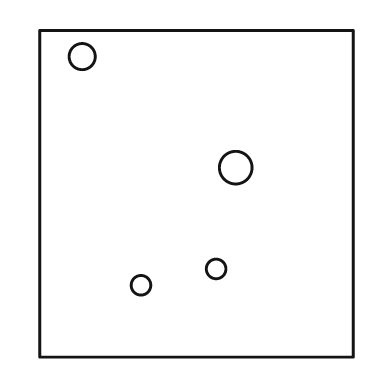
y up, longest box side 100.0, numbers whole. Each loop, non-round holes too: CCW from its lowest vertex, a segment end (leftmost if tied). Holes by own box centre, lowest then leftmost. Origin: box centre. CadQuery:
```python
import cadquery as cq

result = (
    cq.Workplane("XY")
    .moveTo(-48.0, -50.0)
    .lineTo(48.0, -50.0)
    .lineTo(48.0, 50.0)
    .lineTo(-48.0, 50.0)
    .close()
    .moveTo(-17.0, -28.0)
    .circle(3.0)
    .moveTo(6.0, -23.0)
    .circle(3.0)
    .moveTo(12.0, 8.0)
    .circle(5.0)
    .moveTo(-35.0, 42.0)
    .circle(4.0)
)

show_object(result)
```